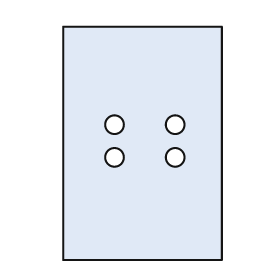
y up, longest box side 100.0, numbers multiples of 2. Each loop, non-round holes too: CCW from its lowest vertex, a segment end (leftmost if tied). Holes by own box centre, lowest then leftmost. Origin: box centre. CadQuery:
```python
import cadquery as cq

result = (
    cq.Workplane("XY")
    .moveTo(-34.0, -50.0)
    .lineTo(34.0, -50.0)
    .lineTo(34.0, 50.0)
    .lineTo(-34.0, 50.0)
    .close()
    .moveTo(-12.0, -6.0)
    .circle(4.0)
    .moveTo(14.0, -6.0)
    .circle(4.0)
    .moveTo(-12.0, 8.0)
    .circle(4.0)
    .moveTo(14.0, 8.0)
    .circle(4.0)
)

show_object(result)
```